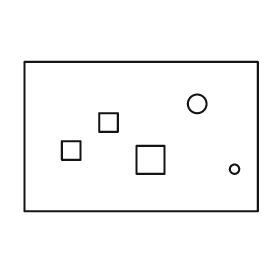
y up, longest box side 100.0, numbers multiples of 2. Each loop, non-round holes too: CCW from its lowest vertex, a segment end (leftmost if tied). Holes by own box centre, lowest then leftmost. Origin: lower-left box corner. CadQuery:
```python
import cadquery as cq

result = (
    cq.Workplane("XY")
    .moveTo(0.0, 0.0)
    .lineTo(100.0, 0.0)
    .lineTo(100.0, 64.0)
    .lineTo(0.0, 64.0)
    .close()
    .moveTo(90.0, 18.0)
    .circle(2.0)
    .moveTo(48.0, 16.0)
    .lineTo(60.0, 16.0)
    .lineTo(60.0, 28.0)
    .lineTo(48.0, 28.0)
    .close()
    .moveTo(16.0, 22.0)
    .lineTo(24.0, 22.0)
    .lineTo(24.0, 30.0)
    .lineTo(16.0, 30.0)
    .close()
    .moveTo(32.0, 34.0)
    .lineTo(40.0, 34.0)
    .lineTo(40.0, 42.0)
    .lineTo(32.0, 42.0)
    .close()
    .moveTo(74.0, 46.0)
    .circle(4.0)
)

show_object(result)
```